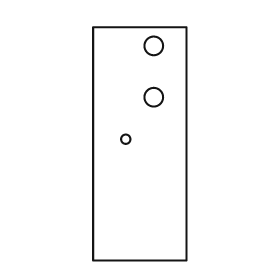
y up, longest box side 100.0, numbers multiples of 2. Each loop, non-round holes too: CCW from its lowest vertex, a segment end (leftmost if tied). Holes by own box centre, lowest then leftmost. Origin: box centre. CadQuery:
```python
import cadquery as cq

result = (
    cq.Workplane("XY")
    .moveTo(-20.0, -50.0)
    .lineTo(20.0, -50.0)
    .lineTo(20.0, 50.0)
    .lineTo(-20.0, 50.0)
    .close()
    .moveTo(-6.0, 2.0)
    .circle(2.0)
    .moveTo(6.0, 20.0)
    .circle(4.0)
    .moveTo(6.0, 42.0)
    .circle(4.0)
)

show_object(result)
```